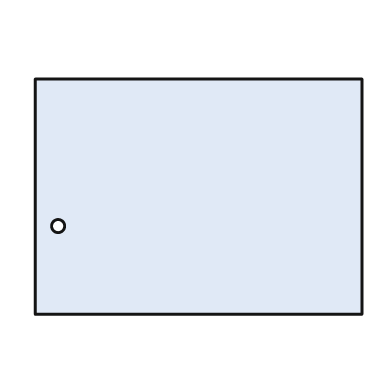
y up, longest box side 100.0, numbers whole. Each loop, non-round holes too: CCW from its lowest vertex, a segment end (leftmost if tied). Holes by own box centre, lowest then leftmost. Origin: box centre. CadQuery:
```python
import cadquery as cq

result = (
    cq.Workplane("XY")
    .moveTo(-50.0, -36.0)
    .lineTo(50.0, -36.0)
    .lineTo(50.0, 36.0)
    .lineTo(-50.0, 36.0)
    .close()
    .moveTo(-43.0, -9.0)
    .circle(2.0)
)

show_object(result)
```